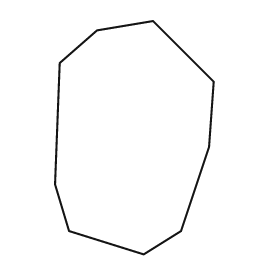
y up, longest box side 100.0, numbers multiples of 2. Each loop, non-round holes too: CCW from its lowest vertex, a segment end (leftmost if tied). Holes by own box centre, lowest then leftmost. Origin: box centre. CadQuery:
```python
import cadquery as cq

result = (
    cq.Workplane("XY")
    .moveTo(4.0, -50.0)
    .lineTo(20.0, -40.0)
    .lineTo(32.0, -4.0)
    .lineTo(34.0, 24.0)
    .lineTo(8.0, 50.0)
    .lineTo(-16.0, 46.0)
    .lineTo(-32.0, 32.0)
    .lineTo(-34.0, -20.0)
    .lineTo(-28.0, -40.0)
    .close()
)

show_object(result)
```